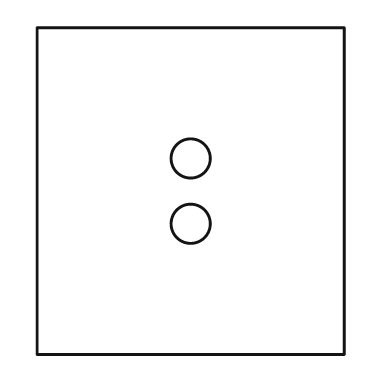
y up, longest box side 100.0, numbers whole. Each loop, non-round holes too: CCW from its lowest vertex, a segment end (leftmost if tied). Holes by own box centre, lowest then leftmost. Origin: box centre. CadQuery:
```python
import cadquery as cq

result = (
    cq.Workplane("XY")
    .moveTo(-47.0, -50.0)
    .lineTo(47.0, -50.0)
    .lineTo(47.0, 50.0)
    .lineTo(-47.0, 50.0)
    .close()
    .moveTo(0.0, -10.0)
    .circle(6.0)
    .moveTo(0.0, 10.0)
    .circle(6.0)
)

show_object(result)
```